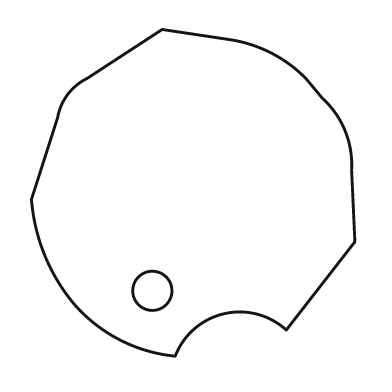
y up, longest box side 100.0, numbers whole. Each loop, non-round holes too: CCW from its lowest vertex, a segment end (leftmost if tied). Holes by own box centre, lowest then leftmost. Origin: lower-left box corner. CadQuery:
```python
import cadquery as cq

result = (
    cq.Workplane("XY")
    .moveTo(44.0, 0.0)
    .threePointArc((59.0, 13.0), (78.0, 8.0))
    .lineTo(99.0, 35.0)
    .lineTo(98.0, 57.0)
    .threePointArc((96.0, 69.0), (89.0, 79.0))
    .lineTo(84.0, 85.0)
    .threePointArc((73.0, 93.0), (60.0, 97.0))
    .lineTo(40.0, 100.0)
    .lineTo(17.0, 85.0)
    .threePointArc((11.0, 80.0), (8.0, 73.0))
    .lineTo(0.0, 48.0)
    .threePointArc((4.0, 31.0), (13.0, 16.0))
    .threePointArc((27.0, 5.0), (44.0, 0.0))
    .close()
    .moveTo(37.0, 20.0)
    .circle(6.0)
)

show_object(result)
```